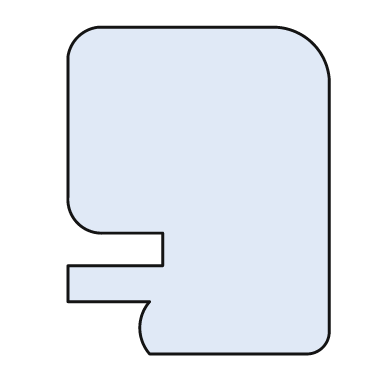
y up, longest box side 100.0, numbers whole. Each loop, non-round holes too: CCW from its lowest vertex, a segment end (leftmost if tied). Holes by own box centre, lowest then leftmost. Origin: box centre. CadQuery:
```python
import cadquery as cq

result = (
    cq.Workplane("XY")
    .moveTo(-15.0, -50.0)
    .lineTo(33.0, -50.0)
    .threePointArc((38.0, -48.0), (40.0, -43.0))
    .lineTo(40.0, 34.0)
    .threePointArc((35.0, 45.0), (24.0, 50.0))
    .lineTo(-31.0, 50.0)
    .threePointArc((-37.0, 47.0), (-40.0, 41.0))
    .lineTo(-40.0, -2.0)
    .threePointArc((-37.0, -10.0), (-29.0, -13.0))
    .lineTo(-11.0, -13.0)
    .lineTo(-11.0, -23.0)
    .lineTo(-40.0, -23.0)
    .lineTo(-40.0, -34.0)
    .lineTo(-15.0, -34.0)
    .threePointArc((-18.0, -42.0), (-15.0, -50.0))
    .close()
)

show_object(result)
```